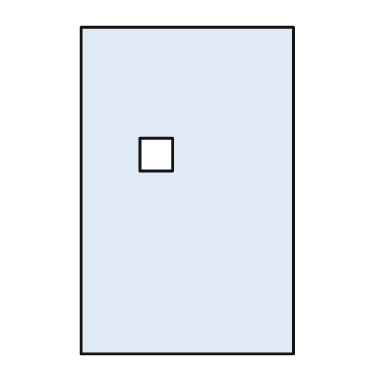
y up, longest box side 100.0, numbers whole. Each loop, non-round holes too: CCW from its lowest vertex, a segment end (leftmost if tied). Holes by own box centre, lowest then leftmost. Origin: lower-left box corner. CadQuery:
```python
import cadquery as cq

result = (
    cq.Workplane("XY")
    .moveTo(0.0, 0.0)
    .lineTo(65.0, 0.0)
    .lineTo(65.0, 100.0)
    .lineTo(0.0, 100.0)
    .close()
    .moveTo(18.0, 56.0)
    .lineTo(28.0, 56.0)
    .lineTo(28.0, 66.0)
    .lineTo(18.0, 66.0)
    .close()
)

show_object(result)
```